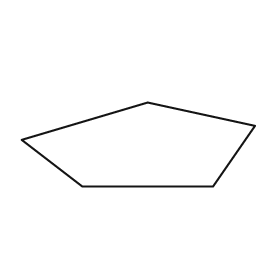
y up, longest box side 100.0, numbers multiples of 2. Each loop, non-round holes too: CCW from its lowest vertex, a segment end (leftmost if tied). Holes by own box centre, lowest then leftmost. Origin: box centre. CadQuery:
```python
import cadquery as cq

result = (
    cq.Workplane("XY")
    .moveTo(-24.0, -18.0)
    .lineTo(32.0, -18.0)
    .lineTo(50.0, 8.0)
    .lineTo(4.0, 18.0)
    .lineTo(-50.0, 2.0)
    .close()
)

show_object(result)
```